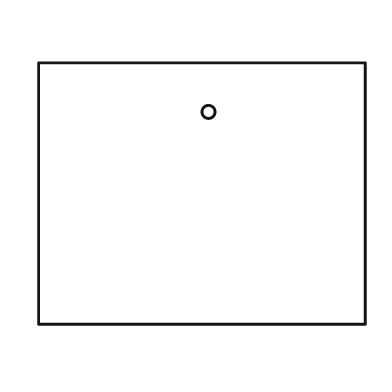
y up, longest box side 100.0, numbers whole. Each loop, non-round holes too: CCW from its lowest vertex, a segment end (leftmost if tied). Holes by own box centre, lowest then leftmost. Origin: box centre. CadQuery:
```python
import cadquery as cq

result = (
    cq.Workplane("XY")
    .moveTo(-50.0, -40.0)
    .lineTo(50.0, -40.0)
    .lineTo(50.0, 40.0)
    .lineTo(-50.0, 40.0)
    .close()
    .moveTo(2.0, 25.0)
    .circle(2.0)
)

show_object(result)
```